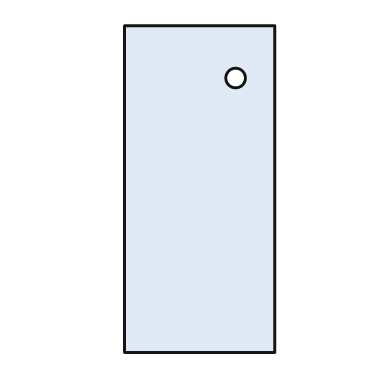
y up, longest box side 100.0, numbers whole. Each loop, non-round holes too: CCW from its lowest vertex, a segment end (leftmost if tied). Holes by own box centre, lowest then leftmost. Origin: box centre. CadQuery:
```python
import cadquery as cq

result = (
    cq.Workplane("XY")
    .moveTo(-23.0, -50.0)
    .lineTo(23.0, -50.0)
    .lineTo(23.0, 50.0)
    .lineTo(-23.0, 50.0)
    .close()
    .moveTo(11.0, 34.0)
    .circle(3.0)
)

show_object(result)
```